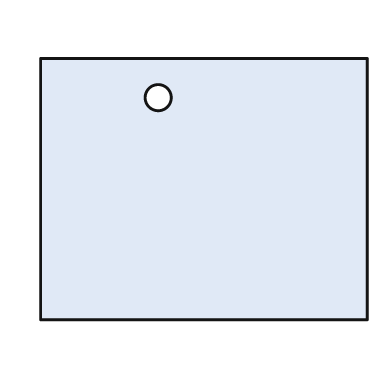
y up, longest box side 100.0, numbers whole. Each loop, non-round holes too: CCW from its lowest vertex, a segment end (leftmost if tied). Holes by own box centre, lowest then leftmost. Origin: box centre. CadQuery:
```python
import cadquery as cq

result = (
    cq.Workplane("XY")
    .moveTo(-50.0, -40.0)
    .lineTo(50.0, -40.0)
    .lineTo(50.0, 40.0)
    .lineTo(-50.0, 40.0)
    .close()
    .moveTo(-14.0, 28.0)
    .circle(4.0)
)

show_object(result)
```